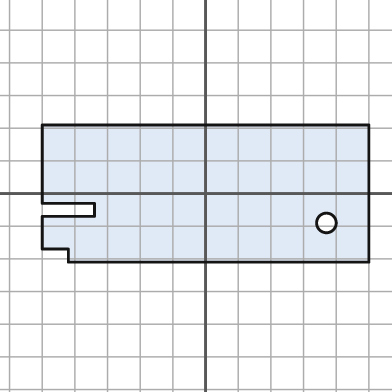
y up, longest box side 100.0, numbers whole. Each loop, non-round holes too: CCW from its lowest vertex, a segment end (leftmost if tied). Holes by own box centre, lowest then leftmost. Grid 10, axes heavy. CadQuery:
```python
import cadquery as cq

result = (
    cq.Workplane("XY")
    .moveTo(-42.0, -21.0)
    .lineTo(50.0, -21.0)
    .lineTo(50.0, 21.0)
    .lineTo(-50.0, 21.0)
    .lineTo(-50.0, -3.0)
    .lineTo(-34.0, -3.0)
    .lineTo(-34.0, -7.0)
    .lineTo(-50.0, -7.0)
    .lineTo(-50.0, -17.0)
    .lineTo(-42.0, -17.0)
    .close()
    .moveTo(37.0, -9.0)
    .circle(3.0)
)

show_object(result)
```